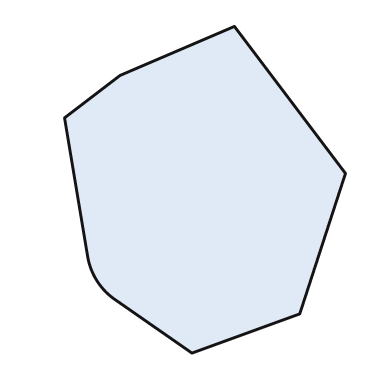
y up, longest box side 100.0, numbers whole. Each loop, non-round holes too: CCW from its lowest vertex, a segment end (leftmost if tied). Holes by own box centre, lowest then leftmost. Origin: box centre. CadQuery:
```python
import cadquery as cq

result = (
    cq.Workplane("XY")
    .moveTo(-4.0, -50.0)
    .lineTo(29.0, -38.0)
    .lineTo(43.0, 5.0)
    .lineTo(9.0, 50.0)
    .lineTo(-26.0, 35.0)
    .lineTo(-43.0, 22.0)
    .lineTo(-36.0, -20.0)
    .threePointArc((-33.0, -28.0), (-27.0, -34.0))
    .close()
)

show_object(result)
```